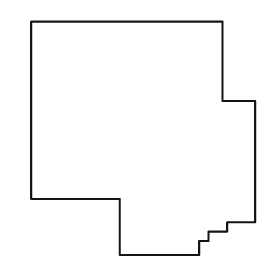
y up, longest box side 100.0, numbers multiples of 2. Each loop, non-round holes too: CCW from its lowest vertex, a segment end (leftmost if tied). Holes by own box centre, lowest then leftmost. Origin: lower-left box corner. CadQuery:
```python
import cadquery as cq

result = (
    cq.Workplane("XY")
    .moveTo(38.0, 0.0)
    .lineTo(72.0, 0.0)
    .lineTo(72.0, 6.0)
    .lineTo(76.0, 6.0)
    .lineTo(76.0, 10.0)
    .lineTo(84.0, 10.0)
    .lineTo(84.0, 14.0)
    .lineTo(96.0, 14.0)
    .lineTo(96.0, 66.0)
    .lineTo(82.0, 66.0)
    .lineTo(82.0, 100.0)
    .lineTo(0.0, 100.0)
    .lineTo(0.0, 24.0)
    .lineTo(38.0, 24.0)
    .close()
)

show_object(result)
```